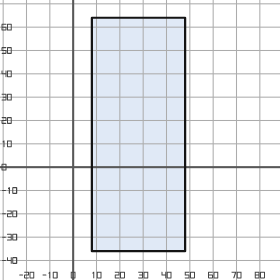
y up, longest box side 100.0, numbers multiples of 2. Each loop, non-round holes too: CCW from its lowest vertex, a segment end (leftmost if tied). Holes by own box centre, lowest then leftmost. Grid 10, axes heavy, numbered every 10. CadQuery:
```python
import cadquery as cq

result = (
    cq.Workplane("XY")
    .moveTo(8.0, -36.0)
    .lineTo(48.0, -36.0)
    .lineTo(48.0, 64.0)
    .lineTo(8.0, 64.0)
    .close()
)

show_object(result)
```